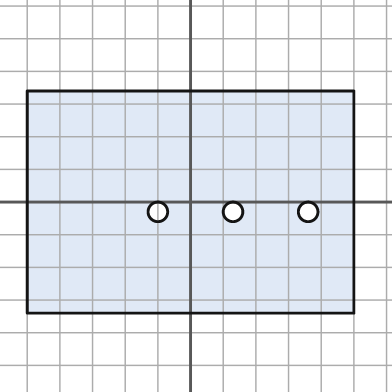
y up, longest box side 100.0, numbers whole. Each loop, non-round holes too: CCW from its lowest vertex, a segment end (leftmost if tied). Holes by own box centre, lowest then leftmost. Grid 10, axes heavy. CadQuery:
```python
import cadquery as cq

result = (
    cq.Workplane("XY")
    .moveTo(-50.0, -34.0)
    .lineTo(50.0, -34.0)
    .lineTo(50.0, 34.0)
    .lineTo(-50.0, 34.0)
    .close()
    .moveTo(-10.0, -3.0)
    .circle(3.0)
    .moveTo(13.0, -3.0)
    .circle(3.0)
    .moveTo(36.0, -3.0)
    .circle(3.0)
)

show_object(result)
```